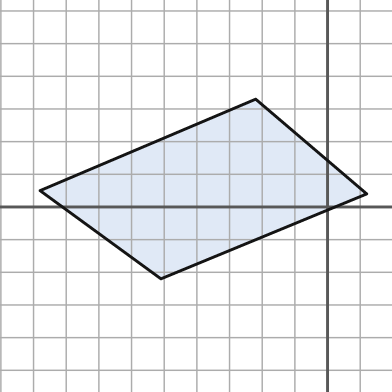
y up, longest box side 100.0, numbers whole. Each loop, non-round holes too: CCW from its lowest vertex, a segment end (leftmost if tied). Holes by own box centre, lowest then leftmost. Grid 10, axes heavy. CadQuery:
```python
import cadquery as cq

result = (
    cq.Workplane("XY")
    .moveTo(-51.0, -22.0)
    .lineTo(12.0, 4.0)
    .lineTo(-22.0, 33.0)
    .lineTo(-88.0, 5.0)
    .close()
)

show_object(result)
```